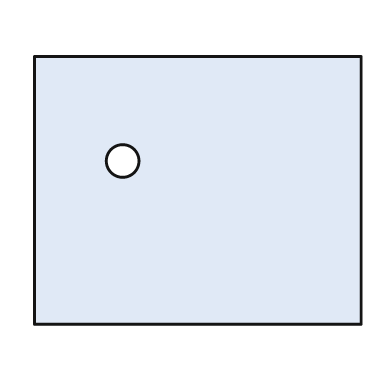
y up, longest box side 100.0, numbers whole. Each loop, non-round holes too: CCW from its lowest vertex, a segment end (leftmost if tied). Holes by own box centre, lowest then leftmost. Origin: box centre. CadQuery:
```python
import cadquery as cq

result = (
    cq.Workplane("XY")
    .moveTo(-50.0, -41.0)
    .lineTo(50.0, -41.0)
    .lineTo(50.0, 41.0)
    .lineTo(-50.0, 41.0)
    .close()
    .moveTo(-23.0, 9.0)
    .circle(5.0)
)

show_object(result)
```